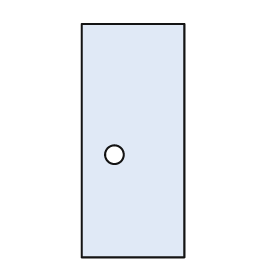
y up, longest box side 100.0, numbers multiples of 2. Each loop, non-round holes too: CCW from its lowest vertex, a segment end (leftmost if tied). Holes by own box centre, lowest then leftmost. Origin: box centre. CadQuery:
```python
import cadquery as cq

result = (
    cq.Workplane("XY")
    .moveTo(-22.0, -50.0)
    .lineTo(22.0, -50.0)
    .lineTo(22.0, 50.0)
    .lineTo(-22.0, 50.0)
    .close()
    .moveTo(-8.0, -6.0)
    .circle(4.0)
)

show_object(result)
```